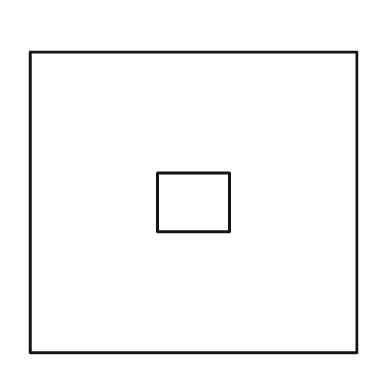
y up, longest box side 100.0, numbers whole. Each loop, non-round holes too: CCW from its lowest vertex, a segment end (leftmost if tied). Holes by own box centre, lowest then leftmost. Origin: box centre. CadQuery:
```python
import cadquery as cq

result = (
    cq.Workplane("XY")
    .moveTo(-50.0, -46.0)
    .lineTo(50.0, -46.0)
    .lineTo(50.0, 46.0)
    .lineTo(-50.0, 46.0)
    .close()
    .moveTo(-11.0, -9.0)
    .lineTo(11.0, -9.0)
    .lineTo(11.0, 9.0)
    .lineTo(-11.0, 9.0)
    .close()
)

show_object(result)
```